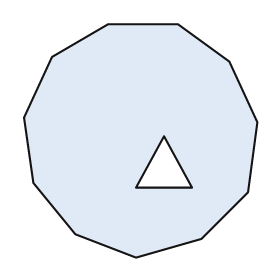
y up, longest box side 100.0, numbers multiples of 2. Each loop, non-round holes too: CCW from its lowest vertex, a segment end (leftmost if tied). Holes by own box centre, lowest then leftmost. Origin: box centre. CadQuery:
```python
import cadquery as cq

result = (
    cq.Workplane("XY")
    .moveTo(-2.0, -50.0)
    .lineTo(26.0, -42.0)
    .lineTo(46.0, -22.0)
    .lineTo(50.0, 8.0)
    .lineTo(38.0, 34.0)
    .lineTo(16.0, 50.0)
    .lineTo(-14.0, 50.0)
    .lineTo(-38.0, 36.0)
    .lineTo(-50.0, 10.0)
    .lineTo(-46.0, -18.0)
    .lineTo(-28.0, -40.0)
    .close()
    .moveTo(-2.0, -20.0)
    .lineTo(22.0, -20.0)
    .lineTo(10.0, 2.0)
    .close()
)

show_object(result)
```